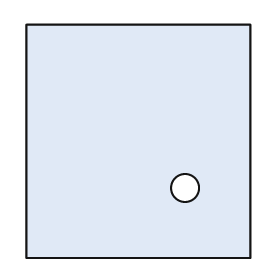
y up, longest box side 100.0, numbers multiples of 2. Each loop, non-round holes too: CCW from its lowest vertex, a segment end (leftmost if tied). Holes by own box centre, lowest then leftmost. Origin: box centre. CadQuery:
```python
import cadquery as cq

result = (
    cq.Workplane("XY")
    .moveTo(-48.0, -50.0)
    .lineTo(48.0, -50.0)
    .lineTo(48.0, 50.0)
    .lineTo(-48.0, 50.0)
    .close()
    .moveTo(20.0, -20.0)
    .circle(6.0)
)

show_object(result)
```